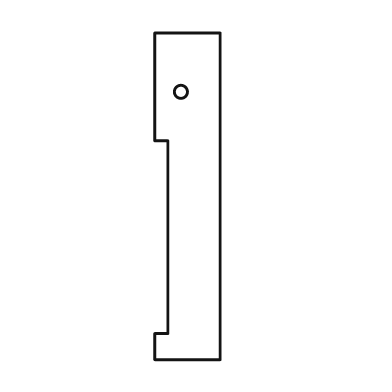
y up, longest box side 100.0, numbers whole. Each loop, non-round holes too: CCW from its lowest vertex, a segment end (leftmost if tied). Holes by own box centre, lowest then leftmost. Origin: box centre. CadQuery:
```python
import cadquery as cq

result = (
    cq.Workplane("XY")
    .moveTo(-10.0, -50.0)
    .lineTo(10.0, -50.0)
    .lineTo(10.0, 50.0)
    .lineTo(-10.0, 50.0)
    .lineTo(-10.0, 17.0)
    .lineTo(-6.0, 17.0)
    .lineTo(-6.0, -42.0)
    .lineTo(-10.0, -42.0)
    .close()
    .moveTo(-2.0, 32.0)
    .circle(2.0)
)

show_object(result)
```